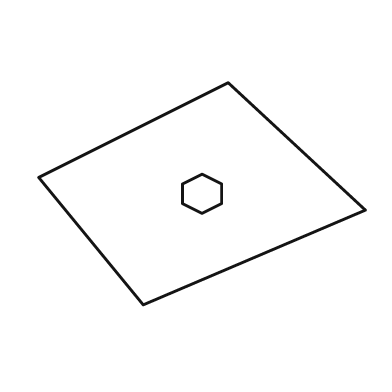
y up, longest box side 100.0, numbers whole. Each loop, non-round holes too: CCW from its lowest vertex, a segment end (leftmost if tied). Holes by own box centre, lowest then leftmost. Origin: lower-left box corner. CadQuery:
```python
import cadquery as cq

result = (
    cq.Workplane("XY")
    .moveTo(32.0, 0.0)
    .lineTo(100.0, 29.0)
    .lineTo(58.0, 68.0)
    .lineTo(0.0, 39.0)
    .close()
    .moveTo(50.0, 28.0)
    .lineTo(56.0, 31.0)
    .lineTo(56.0, 37.0)
    .lineTo(50.0, 40.0)
    .lineTo(44.0, 37.0)
    .lineTo(44.0, 31.0)
    .close()
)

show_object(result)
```